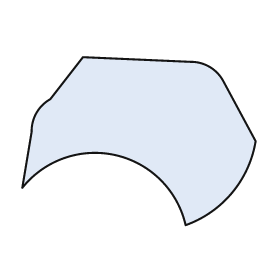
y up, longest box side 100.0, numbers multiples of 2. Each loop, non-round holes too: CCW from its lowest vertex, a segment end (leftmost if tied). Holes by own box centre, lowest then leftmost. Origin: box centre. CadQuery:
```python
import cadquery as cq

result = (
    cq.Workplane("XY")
    .moveTo(20.0, -36.0)
    .threePointArc((40.0, -22.0), (50.0, 0.0))
    .lineTo(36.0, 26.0)
    .threePointArc((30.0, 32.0), (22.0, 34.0))
    .lineTo(-24.0, 36.0)
    .lineTo(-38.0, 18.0)
    .threePointArc((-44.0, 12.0), (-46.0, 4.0))
    .lineTo(-50.0, -20.0)
    .threePointArc((-10.0, -6.0), (20.0, -36.0))
    .close()
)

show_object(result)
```